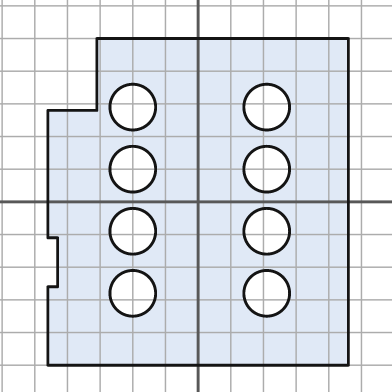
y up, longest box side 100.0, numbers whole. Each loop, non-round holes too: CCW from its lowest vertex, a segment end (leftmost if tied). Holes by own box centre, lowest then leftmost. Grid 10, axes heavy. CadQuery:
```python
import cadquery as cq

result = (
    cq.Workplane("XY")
    .moveTo(-46.0, -50.0)
    .lineTo(46.0, -50.0)
    .lineTo(46.0, 50.0)
    .lineTo(-31.0, 50.0)
    .lineTo(-31.0, 28.0)
    .lineTo(-46.0, 28.0)
    .lineTo(-46.0, -11.0)
    .lineTo(-43.0, -11.0)
    .lineTo(-43.0, -26.0)
    .lineTo(-46.0, -26.0)
    .close()
    .moveTo(-20.0, -28.0)
    .circle(7.0)
    .moveTo(21.0, -28.0)
    .circle(7.0)
    .moveTo(-20.0, -9.0)
    .circle(7.0)
    .moveTo(21.0, -9.0)
    .circle(7.0)
    .moveTo(-20.0, 10.0)
    .circle(7.0)
    .moveTo(21.0, 10.0)
    .circle(7.0)
    .moveTo(-20.0, 29.0)
    .circle(7.0)
    .moveTo(21.0, 29.0)
    .circle(7.0)
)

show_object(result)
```